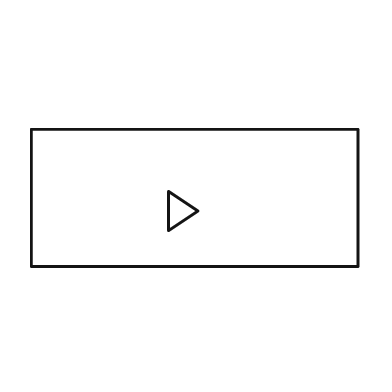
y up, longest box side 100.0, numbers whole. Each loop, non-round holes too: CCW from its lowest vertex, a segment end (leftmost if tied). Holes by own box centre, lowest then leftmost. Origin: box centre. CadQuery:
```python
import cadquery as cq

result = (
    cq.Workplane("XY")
    .moveTo(-50.0, -21.0)
    .lineTo(50.0, -21.0)
    .lineTo(50.0, 21.0)
    .lineTo(-50.0, 21.0)
    .close()
    .moveTo(-8.0, -10.0)
    .lineTo(1.0, -4.0)
    .lineTo(-8.0, 2.0)
    .close()
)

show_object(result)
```